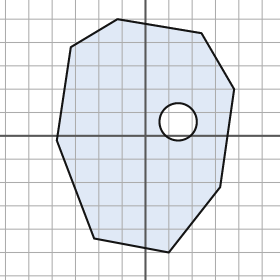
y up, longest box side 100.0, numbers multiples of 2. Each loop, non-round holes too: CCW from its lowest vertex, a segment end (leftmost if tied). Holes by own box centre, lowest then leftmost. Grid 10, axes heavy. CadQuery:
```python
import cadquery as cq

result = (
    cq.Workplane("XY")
    .moveTo(10.0, -50.0)
    .lineTo(32.0, -22.0)
    .lineTo(38.0, 20.0)
    .lineTo(24.0, 44.0)
    .lineTo(-12.0, 50.0)
    .lineTo(-32.0, 38.0)
    .lineTo(-38.0, -2.0)
    .lineTo(-22.0, -44.0)
    .close()
    .moveTo(14.0, 6.0)
    .circle(8.0)
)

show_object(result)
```